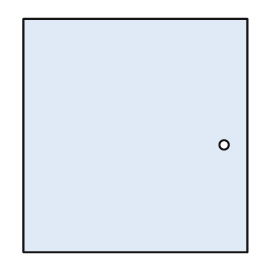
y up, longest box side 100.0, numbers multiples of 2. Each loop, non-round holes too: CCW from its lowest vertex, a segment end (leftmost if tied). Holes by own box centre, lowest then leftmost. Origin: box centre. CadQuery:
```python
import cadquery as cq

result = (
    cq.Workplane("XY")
    .moveTo(-48.0, -50.0)
    .lineTo(48.0, -50.0)
    .lineTo(48.0, 50.0)
    .lineTo(-48.0, 50.0)
    .close()
    .moveTo(38.0, -4.0)
    .circle(2.0)
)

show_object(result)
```